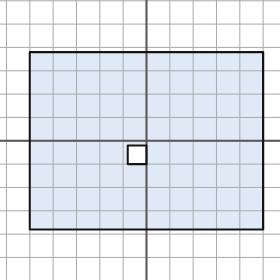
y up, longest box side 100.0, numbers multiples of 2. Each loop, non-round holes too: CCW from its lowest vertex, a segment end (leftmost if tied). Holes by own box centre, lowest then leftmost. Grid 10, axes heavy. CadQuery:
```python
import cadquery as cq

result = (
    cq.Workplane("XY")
    .moveTo(-50.0, -38.0)
    .lineTo(50.0, -38.0)
    .lineTo(50.0, 38.0)
    .lineTo(-50.0, 38.0)
    .close()
    .moveTo(-8.0, -10.0)
    .lineTo(0.0, -10.0)
    .lineTo(0.0, -2.0)
    .lineTo(-8.0, -2.0)
    .close()
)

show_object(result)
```